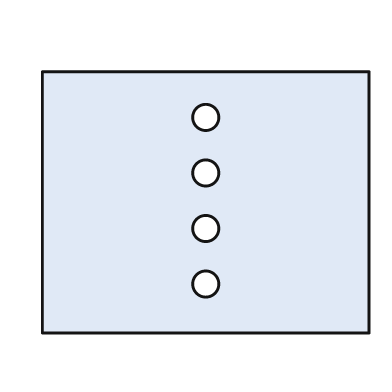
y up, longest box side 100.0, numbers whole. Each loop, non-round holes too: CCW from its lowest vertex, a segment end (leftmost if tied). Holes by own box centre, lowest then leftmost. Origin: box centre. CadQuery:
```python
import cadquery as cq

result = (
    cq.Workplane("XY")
    .moveTo(-50.0, -40.0)
    .lineTo(50.0, -40.0)
    .lineTo(50.0, 40.0)
    .lineTo(-50.0, 40.0)
    .close()
    .moveTo(0.0, -25.0)
    .circle(4.0)
    .moveTo(0.0, -8.0)
    .circle(4.0)
    .moveTo(0.0, 9.0)
    .circle(4.0)
    .moveTo(0.0, 26.0)
    .circle(4.0)
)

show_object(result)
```